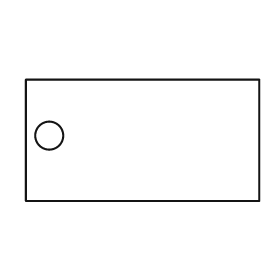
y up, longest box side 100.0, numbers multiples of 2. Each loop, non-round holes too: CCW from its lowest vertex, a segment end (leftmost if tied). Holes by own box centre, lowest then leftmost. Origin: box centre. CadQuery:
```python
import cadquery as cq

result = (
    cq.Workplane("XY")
    .moveTo(-50.0, -26.0)
    .lineTo(50.0, -26.0)
    .lineTo(50.0, 26.0)
    .lineTo(-50.0, 26.0)
    .close()
    .moveTo(-40.0, 2.0)
    .circle(6.0)
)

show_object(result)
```